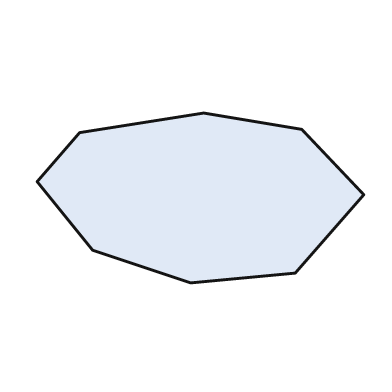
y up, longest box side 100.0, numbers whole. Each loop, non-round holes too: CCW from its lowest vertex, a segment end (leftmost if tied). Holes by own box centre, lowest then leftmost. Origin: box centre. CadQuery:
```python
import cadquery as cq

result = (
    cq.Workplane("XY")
    .moveTo(-3.0, -26.0)
    .lineTo(29.0, -23.0)
    .lineTo(50.0, 1.0)
    .lineTo(31.0, 21.0)
    .lineTo(1.0, 26.0)
    .lineTo(-37.0, 20.0)
    .lineTo(-50.0, 5.0)
    .lineTo(-33.0, -16.0)
    .close()
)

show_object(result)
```